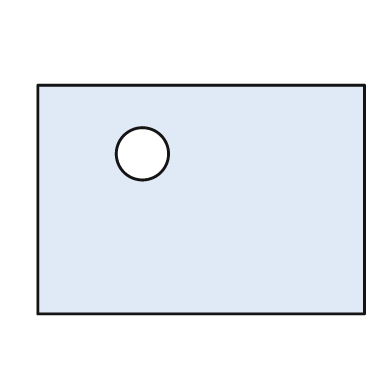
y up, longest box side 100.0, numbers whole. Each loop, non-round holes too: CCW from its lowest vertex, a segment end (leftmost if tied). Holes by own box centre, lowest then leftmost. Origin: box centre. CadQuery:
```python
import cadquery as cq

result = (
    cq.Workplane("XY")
    .moveTo(-50.0, -35.0)
    .lineTo(50.0, -35.0)
    .lineTo(50.0, 35.0)
    .lineTo(-50.0, 35.0)
    .close()
    .moveTo(-18.0, 14.0)
    .circle(8.0)
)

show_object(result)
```